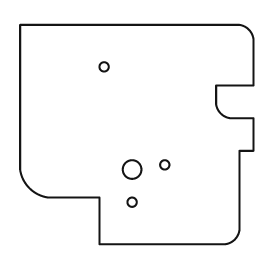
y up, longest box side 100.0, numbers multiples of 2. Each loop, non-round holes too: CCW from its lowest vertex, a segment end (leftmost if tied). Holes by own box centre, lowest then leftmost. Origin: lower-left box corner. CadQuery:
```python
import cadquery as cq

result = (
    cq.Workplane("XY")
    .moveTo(34.0, 0.0)
    .lineTo(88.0, 0.0)
    .threePointArc((92.0, 2.0), (94.0, 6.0))
    .lineTo(94.0, 40.0)
    .lineTo(100.0, 40.0)
    .lineTo(100.0, 54.0)
    .lineTo(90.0, 54.0)
    .threePointArc((86.0, 56.0), (84.0, 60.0))
    .lineTo(84.0, 68.0)
    .lineTo(100.0, 68.0)
    .lineTo(100.0, 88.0)
    .threePointArc((98.0, 92.0), (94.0, 94.0))
    .lineTo(0.0, 94.0)
    .lineTo(0.0, 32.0)
    .threePointArc((4.0, 24.0), (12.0, 20.0))
    .lineTo(34.0, 20.0)
    .close()
    .moveTo(48.0, 18.0)
    .circle(2.0)
    .moveTo(48.0, 32.0)
    .circle(4.0)
    .moveTo(62.0, 34.0)
    .circle(2.0)
    .moveTo(36.0, 76.0)
    .circle(2.0)
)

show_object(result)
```